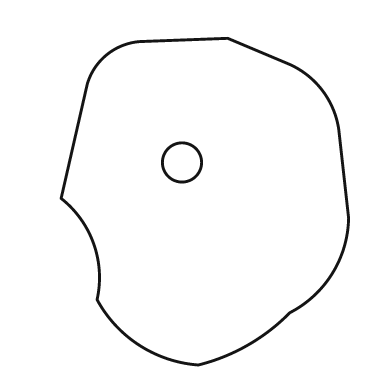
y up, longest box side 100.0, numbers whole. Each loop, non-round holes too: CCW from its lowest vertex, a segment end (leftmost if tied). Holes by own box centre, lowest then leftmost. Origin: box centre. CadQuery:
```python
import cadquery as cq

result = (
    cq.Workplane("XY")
    .moveTo(-2.0, -50.0)
    .threePointArc((13.0, -44.0), (26.0, -34.0))
    .threePointArc((39.0, -22.0), (44.0, -5.0))
    .lineTo(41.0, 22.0)
    .threePointArc((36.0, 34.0), (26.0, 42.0))
    .lineTo(7.0, 50.0)
    .lineTo(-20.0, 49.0)
    .threePointArc((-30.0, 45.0), (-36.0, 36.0))
    .lineTo(-44.0, 1.0)
    .threePointArc((-34.0, -13.0), (-33.0, -30.0))
    .threePointArc((-20.0, -44.0), (-2.0, -50.0))
    .close()
    .moveTo(-7.0, 12.0)
    .circle(6.0)
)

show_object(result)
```